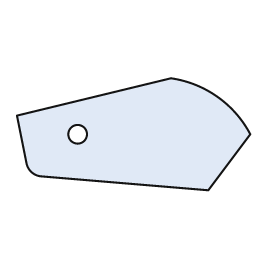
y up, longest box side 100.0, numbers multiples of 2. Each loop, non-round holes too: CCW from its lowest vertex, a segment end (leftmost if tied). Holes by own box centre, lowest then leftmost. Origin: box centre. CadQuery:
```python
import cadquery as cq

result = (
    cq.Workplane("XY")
    .moveTo(32.0, -24.0)
    .lineTo(50.0, 0.0)
    .threePointArc((36.0, 16.0), (16.0, 24.0))
    .lineTo(-50.0, 8.0)
    .lineTo(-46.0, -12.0)
    .threePointArc((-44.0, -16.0), (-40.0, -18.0))
    .close()
    .moveTo(-24.0, 0.0)
    .circle(4.0)
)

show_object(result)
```